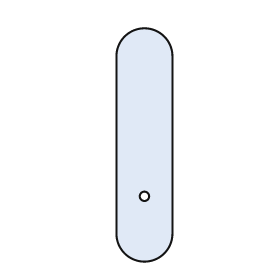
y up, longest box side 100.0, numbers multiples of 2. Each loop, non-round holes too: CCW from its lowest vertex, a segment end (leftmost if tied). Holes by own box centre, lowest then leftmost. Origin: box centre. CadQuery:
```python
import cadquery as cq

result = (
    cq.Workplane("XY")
    .moveTo(-12.0, -38.0)
    .threePointArc((0.0, -50.0), (12.0, -38.0))
    .lineTo(12.0, 38.0)
    .threePointArc((0.0, 50.0), (-12.0, 38.0))
    .close()
    .moveTo(0.0, -22.0)
    .circle(2.0)
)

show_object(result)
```